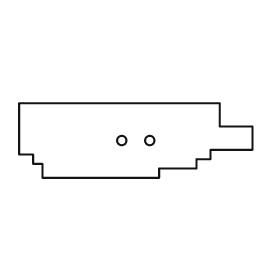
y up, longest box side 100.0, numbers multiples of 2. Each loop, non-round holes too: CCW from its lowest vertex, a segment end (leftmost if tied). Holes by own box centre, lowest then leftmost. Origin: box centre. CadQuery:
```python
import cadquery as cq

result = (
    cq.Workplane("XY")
    .moveTo(-40.0, -16.0)
    .lineTo(10.0, -16.0)
    .lineTo(10.0, -12.0)
    .lineTo(26.0, -12.0)
    .lineTo(26.0, -8.0)
    .lineTo(32.0, -8.0)
    .lineTo(32.0, -4.0)
    .lineTo(50.0, -4.0)
    .lineTo(50.0, 6.0)
    .lineTo(36.0, 6.0)
    .lineTo(36.0, 16.0)
    .lineTo(-50.0, 16.0)
    .lineTo(-50.0, -6.0)
    .lineTo(-44.0, -6.0)
    .lineTo(-44.0, -10.0)
    .lineTo(-40.0, -10.0)
    .close()
    .moveTo(-6.0, 0.0)
    .circle(2.0)
    .moveTo(6.0, 0.0)
    .circle(2.0)
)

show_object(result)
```